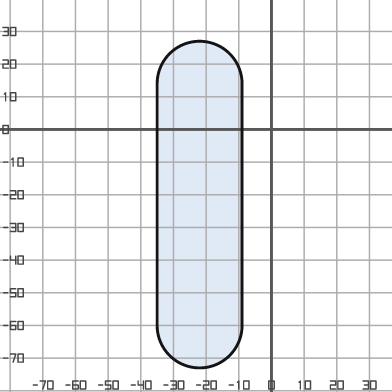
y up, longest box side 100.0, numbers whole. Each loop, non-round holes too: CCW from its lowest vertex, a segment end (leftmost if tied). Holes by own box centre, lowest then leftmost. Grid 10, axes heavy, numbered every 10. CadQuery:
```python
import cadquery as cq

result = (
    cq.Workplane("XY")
    .moveTo(-35.0, -60.0)
    .threePointArc((-22.0, -73.0), (-9.0, -60.0))
    .lineTo(-9.0, 14.0)
    .threePointArc((-22.0, 27.0), (-35.0, 14.0))
    .close()
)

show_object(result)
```